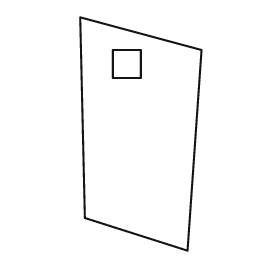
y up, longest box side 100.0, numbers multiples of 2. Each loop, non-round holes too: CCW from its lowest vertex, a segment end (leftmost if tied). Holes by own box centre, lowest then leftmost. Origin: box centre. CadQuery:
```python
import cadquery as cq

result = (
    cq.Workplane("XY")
    .moveTo(20.0, -50.0)
    .lineTo(26.0, 36.0)
    .lineTo(-26.0, 50.0)
    .lineTo(-24.0, -36.0)
    .close()
    .moveTo(-12.0, 24.0)
    .lineTo(0.0, 24.0)
    .lineTo(0.0, 36.0)
    .lineTo(-12.0, 36.0)
    .close()
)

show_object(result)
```